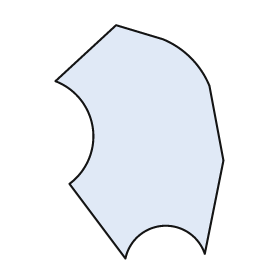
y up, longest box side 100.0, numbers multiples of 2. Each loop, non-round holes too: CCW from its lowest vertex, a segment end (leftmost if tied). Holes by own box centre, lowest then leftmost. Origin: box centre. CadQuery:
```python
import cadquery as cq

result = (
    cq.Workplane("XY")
    .moveTo(-6.0, -50.0)
    .threePointArc((10.0, -36.0), (28.0, -48.0))
    .lineTo(36.0, -8.0)
    .lineTo(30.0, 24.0)
    .threePointArc((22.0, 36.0), (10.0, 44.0))
    .lineTo(-10.0, 50.0)
    .lineTo(-36.0, 26.0)
    .threePointArc((-20.0, 6.0), (-30.0, -18.0))
    .close()
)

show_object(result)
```